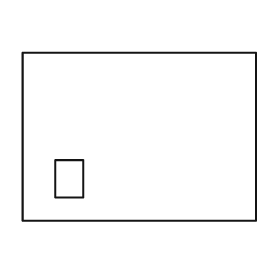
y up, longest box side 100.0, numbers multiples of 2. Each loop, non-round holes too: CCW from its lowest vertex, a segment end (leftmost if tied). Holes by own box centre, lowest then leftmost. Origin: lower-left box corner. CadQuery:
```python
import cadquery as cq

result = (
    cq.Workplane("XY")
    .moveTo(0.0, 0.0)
    .lineTo(100.0, 0.0)
    .lineTo(100.0, 72.0)
    .lineTo(0.0, 72.0)
    .close()
    .moveTo(14.0, 10.0)
    .lineTo(26.0, 10.0)
    .lineTo(26.0, 26.0)
    .lineTo(14.0, 26.0)
    .close()
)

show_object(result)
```